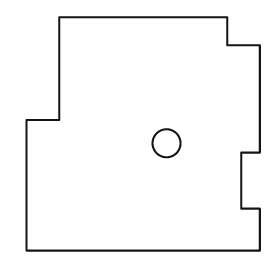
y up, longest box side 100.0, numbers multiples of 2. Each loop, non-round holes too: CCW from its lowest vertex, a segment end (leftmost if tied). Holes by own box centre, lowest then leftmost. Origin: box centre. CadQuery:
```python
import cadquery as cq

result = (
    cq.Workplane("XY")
    .moveTo(-50.0, -50.0)
    .lineTo(50.0, -50.0)
    .lineTo(50.0, -32.0)
    .lineTo(42.0, -32.0)
    .lineTo(42.0, -8.0)
    .lineTo(50.0, -8.0)
    .lineTo(50.0, 38.0)
    .lineTo(36.0, 38.0)
    .lineTo(36.0, 50.0)
    .lineTo(-36.0, 50.0)
    .lineTo(-36.0, 6.0)
    .lineTo(-50.0, 6.0)
    .close()
    .moveTo(10.0, -4.0)
    .circle(6.0)
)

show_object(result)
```